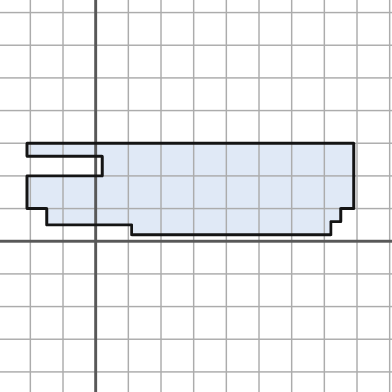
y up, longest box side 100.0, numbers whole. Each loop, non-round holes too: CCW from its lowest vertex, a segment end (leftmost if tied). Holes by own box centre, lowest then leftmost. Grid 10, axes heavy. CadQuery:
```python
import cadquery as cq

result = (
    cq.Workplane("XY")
    .moveTo(11.0, 2.0)
    .lineTo(72.0, 2.0)
    .lineTo(72.0, 6.0)
    .lineTo(75.0, 6.0)
    .lineTo(75.0, 10.0)
    .lineTo(79.0, 10.0)
    .lineTo(79.0, 30.0)
    .lineTo(-21.0, 30.0)
    .lineTo(-21.0, 26.0)
    .lineTo(2.0, 26.0)
    .lineTo(2.0, 20.0)
    .lineTo(-21.0, 20.0)
    .lineTo(-21.0, 10.0)
    .lineTo(-15.0, 10.0)
    .lineTo(-15.0, 5.0)
    .lineTo(11.0, 5.0)
    .close()
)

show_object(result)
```